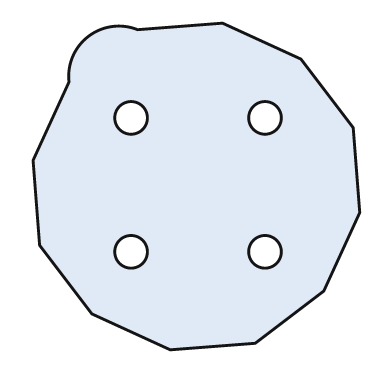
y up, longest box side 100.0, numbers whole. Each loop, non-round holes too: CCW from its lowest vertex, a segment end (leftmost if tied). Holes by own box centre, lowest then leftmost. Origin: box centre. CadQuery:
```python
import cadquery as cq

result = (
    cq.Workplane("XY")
    .moveTo(-8.0, -50.0)
    .lineTo(18.0, -48.0)
    .lineTo(39.0, -32.0)
    .lineTo(50.0, -8.0)
    .lineTo(48.0, 18.0)
    .lineTo(32.0, 39.0)
    .lineTo(8.0, 50.0)
    .lineTo(-18.0, 48.0)
    .threePointArc((-33.0, 46.0), (-39.0, 32.0))
    .lineTo(-50.0, 8.0)
    .lineTo(-48.0, -18.0)
    .lineTo(-32.0, -39.0)
    .close()
    .moveTo(-20.0, -20.0)
    .circle(5.0)
    .moveTo(21.0, -20.0)
    .circle(5.0)
    .moveTo(-20.0, 21.0)
    .circle(5.0)
    .moveTo(21.0, 21.0)
    .circle(5.0)
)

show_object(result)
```